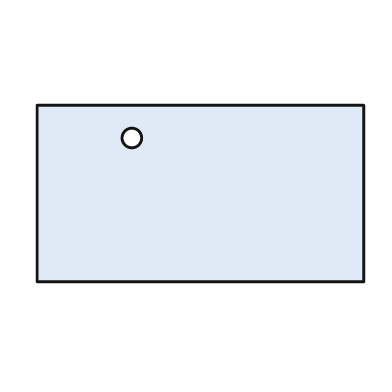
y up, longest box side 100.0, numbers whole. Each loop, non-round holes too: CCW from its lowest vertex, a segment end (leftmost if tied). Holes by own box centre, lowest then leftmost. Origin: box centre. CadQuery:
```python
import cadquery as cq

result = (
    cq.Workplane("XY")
    .moveTo(-50.0, -27.0)
    .lineTo(50.0, -27.0)
    .lineTo(50.0, 27.0)
    .lineTo(-50.0, 27.0)
    .close()
    .moveTo(-21.0, 17.0)
    .circle(3.0)
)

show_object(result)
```